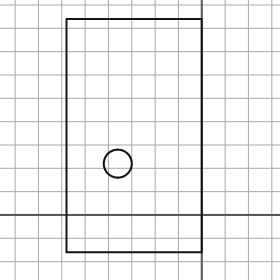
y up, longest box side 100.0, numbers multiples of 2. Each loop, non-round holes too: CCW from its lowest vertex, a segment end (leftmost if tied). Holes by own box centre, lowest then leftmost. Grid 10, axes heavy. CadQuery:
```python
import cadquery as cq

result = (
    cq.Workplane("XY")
    .moveTo(-58.0, -16.0)
    .lineTo(0.0, -16.0)
    .lineTo(0.0, 84.0)
    .lineTo(-58.0, 84.0)
    .close()
    .moveTo(-36.0, 22.0)
    .circle(6.0)
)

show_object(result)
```